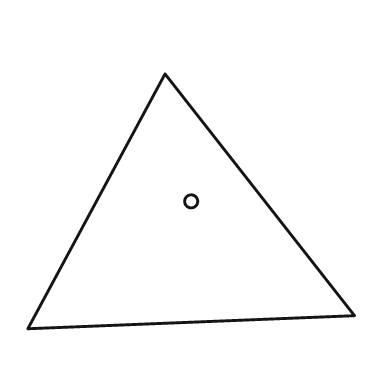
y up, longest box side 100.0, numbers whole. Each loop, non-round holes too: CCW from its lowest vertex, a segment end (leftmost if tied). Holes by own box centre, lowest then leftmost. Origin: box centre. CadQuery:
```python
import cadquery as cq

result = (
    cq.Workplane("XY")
    .moveTo(-50.0, -39.0)
    .lineTo(50.0, -35.0)
    .lineTo(-8.0, 39.0)
    .close()
    .moveTo(0.0, 0.0)
    .circle(2.0)
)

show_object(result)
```